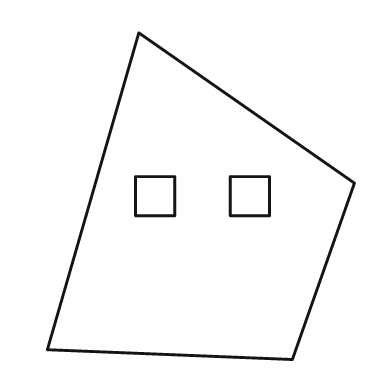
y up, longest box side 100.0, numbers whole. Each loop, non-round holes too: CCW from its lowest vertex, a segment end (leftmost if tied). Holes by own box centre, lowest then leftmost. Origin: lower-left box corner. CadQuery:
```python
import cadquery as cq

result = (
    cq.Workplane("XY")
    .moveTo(75.0, 0.0)
    .lineTo(94.0, 54.0)
    .lineTo(28.0, 100.0)
    .lineTo(0.0, 3.0)
    .close()
    .moveTo(27.0, 44.0)
    .lineTo(39.0, 44.0)
    .lineTo(39.0, 56.0)
    .lineTo(27.0, 56.0)
    .close()
    .moveTo(56.0, 44.0)
    .lineTo(68.0, 44.0)
    .lineTo(68.0, 56.0)
    .lineTo(56.0, 56.0)
    .close()
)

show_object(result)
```